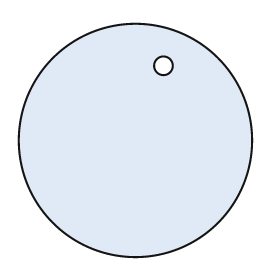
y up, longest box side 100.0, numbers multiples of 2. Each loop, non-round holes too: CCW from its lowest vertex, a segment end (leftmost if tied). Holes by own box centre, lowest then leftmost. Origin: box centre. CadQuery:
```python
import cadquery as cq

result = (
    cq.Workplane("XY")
    .moveTo(0.0, 0.0)
    .circle(50.0)
    .moveTo(12.0, 32.0)
    .circle(4.0)
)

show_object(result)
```